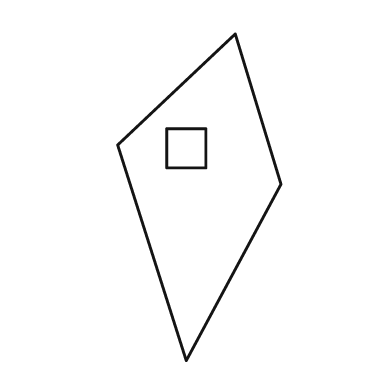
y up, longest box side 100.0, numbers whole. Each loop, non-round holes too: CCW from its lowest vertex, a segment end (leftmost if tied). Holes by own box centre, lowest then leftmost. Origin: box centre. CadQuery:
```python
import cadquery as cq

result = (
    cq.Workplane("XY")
    .moveTo(-4.0, -50.0)
    .lineTo(25.0, 4.0)
    .lineTo(11.0, 50.0)
    .lineTo(-25.0, 16.0)
    .close()
    .moveTo(-10.0, 9.0)
    .lineTo(2.0, 9.0)
    .lineTo(2.0, 21.0)
    .lineTo(-10.0, 21.0)
    .close()
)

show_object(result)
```